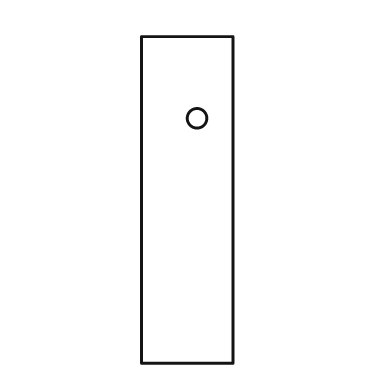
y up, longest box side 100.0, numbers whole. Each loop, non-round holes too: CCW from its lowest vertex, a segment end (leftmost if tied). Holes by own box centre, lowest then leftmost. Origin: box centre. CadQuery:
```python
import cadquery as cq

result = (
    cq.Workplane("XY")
    .moveTo(-14.0, -50.0)
    .lineTo(14.0, -50.0)
    .lineTo(14.0, 50.0)
    .lineTo(-14.0, 50.0)
    .close()
    .moveTo(3.0, 25.0)
    .circle(3.0)
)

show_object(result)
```